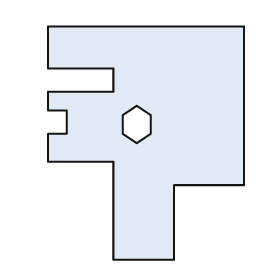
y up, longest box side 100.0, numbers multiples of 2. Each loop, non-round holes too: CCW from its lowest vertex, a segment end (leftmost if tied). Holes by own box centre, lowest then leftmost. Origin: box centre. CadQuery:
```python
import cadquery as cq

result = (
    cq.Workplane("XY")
    .moveTo(-14.0, -50.0)
    .lineTo(12.0, -50.0)
    .lineTo(12.0, -18.0)
    .lineTo(42.0, -18.0)
    .lineTo(42.0, 50.0)
    .lineTo(-42.0, 50.0)
    .lineTo(-42.0, 32.0)
    .lineTo(-14.0, 32.0)
    .lineTo(-14.0, 22.0)
    .lineTo(-42.0, 22.0)
    .lineTo(-42.0, 14.0)
    .lineTo(-34.0, 14.0)
    .lineTo(-34.0, 4.0)
    .lineTo(-42.0, 4.0)
    .lineTo(-42.0, -8.0)
    .lineTo(-14.0, -8.0)
    .close()
    .moveTo(-4.0, 0.0)
    .lineTo(2.0, 4.0)
    .lineTo(2.0, 12.0)
    .lineTo(-4.0, 16.0)
    .lineTo(-10.0, 12.0)
    .lineTo(-10.0, 4.0)
    .close()
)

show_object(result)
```